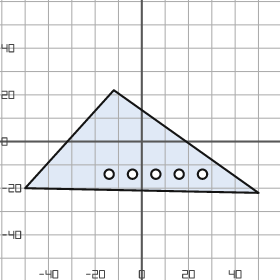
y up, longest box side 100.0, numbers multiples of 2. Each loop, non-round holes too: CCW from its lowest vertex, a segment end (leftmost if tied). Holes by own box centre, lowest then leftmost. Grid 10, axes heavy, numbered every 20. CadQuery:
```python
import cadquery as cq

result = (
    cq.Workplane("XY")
    .moveTo(50.0, -22.0)
    .lineTo(-12.0, 22.0)
    .lineTo(-50.0, -20.0)
    .close()
    .moveTo(-14.0, -14.0)
    .circle(2.0)
    .moveTo(-4.0, -14.0)
    .circle(2.0)
    .moveTo(6.0, -14.0)
    .circle(2.0)
    .moveTo(16.0, -14.0)
    .circle(2.0)
    .moveTo(26.0, -14.0)
    .circle(2.0)
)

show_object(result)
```